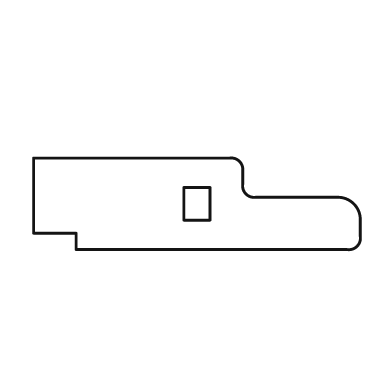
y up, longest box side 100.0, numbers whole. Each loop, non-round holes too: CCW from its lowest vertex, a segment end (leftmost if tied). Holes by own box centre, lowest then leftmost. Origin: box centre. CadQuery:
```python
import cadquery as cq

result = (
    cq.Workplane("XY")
    .moveTo(-37.0, -14.0)
    .lineTo(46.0, -14.0)
    .threePointArc((49.0, -13.0), (50.0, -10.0))
    .lineTo(50.0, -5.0)
    .threePointArc((48.0, 0.0), (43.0, 2.0))
    .lineTo(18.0, 2.0)
    .threePointArc((15.0, 3.0), (14.0, 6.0))
    .lineTo(14.0, 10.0)
    .threePointArc((13.0, 13.0), (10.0, 14.0))
    .lineTo(-50.0, 14.0)
    .lineTo(-50.0, -9.0)
    .lineTo(-37.0, -9.0)
    .close()
    .moveTo(-4.0, -5.0)
    .lineTo(4.0, -5.0)
    .lineTo(4.0, 5.0)
    .lineTo(-4.0, 5.0)
    .close()
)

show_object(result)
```